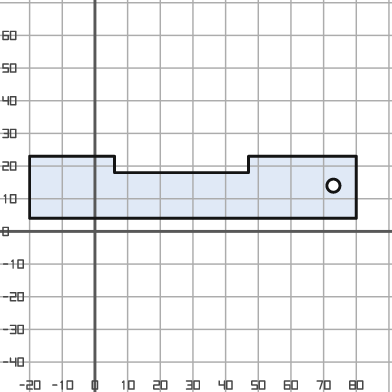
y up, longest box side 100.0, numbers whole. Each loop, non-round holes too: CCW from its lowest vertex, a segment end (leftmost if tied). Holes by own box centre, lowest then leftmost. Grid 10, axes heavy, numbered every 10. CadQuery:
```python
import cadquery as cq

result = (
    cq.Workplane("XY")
    .moveTo(-20.0, 4.0)
    .lineTo(80.0, 4.0)
    .lineTo(80.0, 23.0)
    .lineTo(47.0, 23.0)
    .lineTo(47.0, 18.0)
    .lineTo(6.0, 18.0)
    .lineTo(6.0, 23.0)
    .lineTo(-20.0, 23.0)
    .close()
    .moveTo(73.0, 14.0)
    .circle(2.0)
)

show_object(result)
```